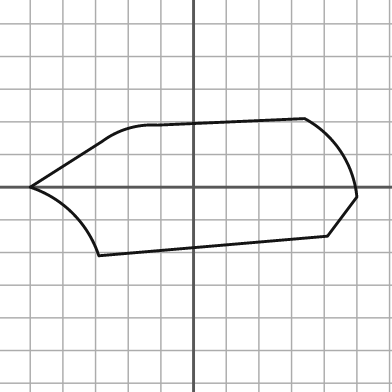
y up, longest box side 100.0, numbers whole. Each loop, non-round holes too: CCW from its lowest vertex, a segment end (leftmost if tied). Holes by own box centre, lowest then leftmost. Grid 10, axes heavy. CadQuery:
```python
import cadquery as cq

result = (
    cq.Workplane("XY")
    .moveTo(-29.0, -21.0)
    .lineTo(41.0, -15.0)
    .lineTo(50.0, -3.0)
    .threePointArc((45.0, 11.0), (34.0, 21.0))
    .lineTo(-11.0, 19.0)
    .threePointArc((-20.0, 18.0), (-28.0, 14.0))
    .lineTo(-50.0, 0.0)
    .threePointArc((-37.0, -8.0), (-29.0, -21.0))
    .close()
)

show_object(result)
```